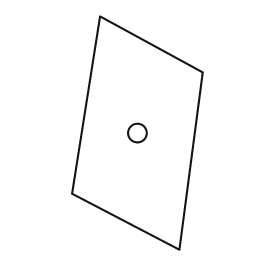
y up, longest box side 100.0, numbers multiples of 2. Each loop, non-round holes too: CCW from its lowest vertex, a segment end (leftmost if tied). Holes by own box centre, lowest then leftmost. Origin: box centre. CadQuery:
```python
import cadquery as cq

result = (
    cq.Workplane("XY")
    .moveTo(18.0, -50.0)
    .lineTo(28.0, 26.0)
    .lineTo(-16.0, 50.0)
    .lineTo(-28.0, -26.0)
    .close()
    .moveTo(0.0, 0.0)
    .circle(4.0)
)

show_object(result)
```